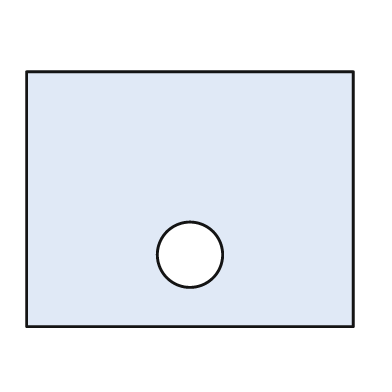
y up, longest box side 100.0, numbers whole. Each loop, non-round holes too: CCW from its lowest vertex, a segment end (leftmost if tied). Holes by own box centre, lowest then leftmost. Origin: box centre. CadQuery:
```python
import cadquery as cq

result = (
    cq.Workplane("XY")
    .moveTo(-50.0, -39.0)
    .lineTo(50.0, -39.0)
    .lineTo(50.0, 39.0)
    .lineTo(-50.0, 39.0)
    .close()
    .moveTo(0.0, -17.0)
    .circle(10.0)
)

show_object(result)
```